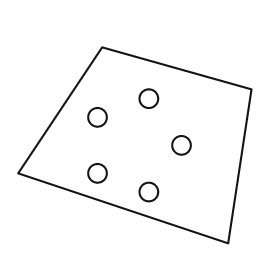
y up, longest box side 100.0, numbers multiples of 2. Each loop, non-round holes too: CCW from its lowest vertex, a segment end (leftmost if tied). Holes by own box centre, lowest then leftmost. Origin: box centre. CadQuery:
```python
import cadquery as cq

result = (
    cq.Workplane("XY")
    .moveTo(40.0, -42.0)
    .lineTo(50.0, 24.0)
    .lineTo(-14.0, 42.0)
    .lineTo(-50.0, -12.0)
    .close()
    .moveTo(6.0, -20.0)
    .circle(4.0)
    .moveTo(-16.0, -12.0)
    .circle(4.0)
    .moveTo(20.0, 0.0)
    .circle(4.0)
    .moveTo(-16.0, 12.0)
    .circle(4.0)
    .moveTo(6.0, 20.0)
    .circle(4.0)
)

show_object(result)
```